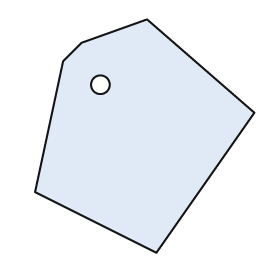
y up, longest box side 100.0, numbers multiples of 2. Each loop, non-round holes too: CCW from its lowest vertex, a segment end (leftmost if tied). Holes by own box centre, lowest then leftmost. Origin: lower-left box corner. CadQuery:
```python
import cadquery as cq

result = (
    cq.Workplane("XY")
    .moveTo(52.0, 0.0)
    .lineTo(94.0, 60.0)
    .lineTo(48.0, 100.0)
    .lineTo(20.0, 90.0)
    .lineTo(12.0, 82.0)
    .lineTo(0.0, 26.0)
    .close()
    .moveTo(28.0, 72.0)
    .circle(4.0)
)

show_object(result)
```